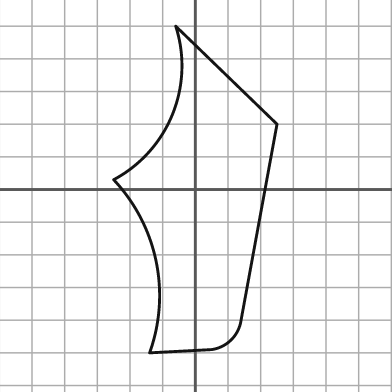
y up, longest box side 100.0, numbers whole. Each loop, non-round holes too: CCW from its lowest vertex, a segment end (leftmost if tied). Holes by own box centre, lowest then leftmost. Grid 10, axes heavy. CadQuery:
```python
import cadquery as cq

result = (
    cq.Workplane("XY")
    .moveTo(-14.0, -50.0)
    .lineTo(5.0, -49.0)
    .threePointArc((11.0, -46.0), (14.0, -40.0))
    .lineTo(25.0, 20.0)
    .lineTo(-6.0, 50.0)
    .threePointArc((-7.0, 23.0), (-25.0, 3.0))
    .threePointArc((-12.0, -22.0), (-14.0, -50.0))
    .close()
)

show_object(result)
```